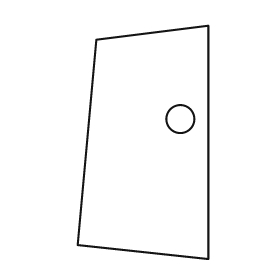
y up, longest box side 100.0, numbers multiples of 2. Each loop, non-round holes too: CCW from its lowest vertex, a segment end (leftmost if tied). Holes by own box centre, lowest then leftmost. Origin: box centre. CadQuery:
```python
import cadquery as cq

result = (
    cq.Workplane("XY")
    .moveTo(28.0, -50.0)
    .lineTo(28.0, 50.0)
    .lineTo(-20.0, 44.0)
    .lineTo(-28.0, -44.0)
    .close()
    .moveTo(16.0, 10.0)
    .circle(6.0)
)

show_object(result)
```